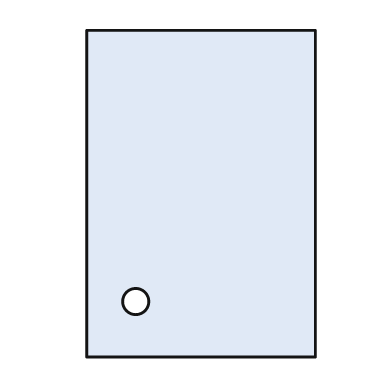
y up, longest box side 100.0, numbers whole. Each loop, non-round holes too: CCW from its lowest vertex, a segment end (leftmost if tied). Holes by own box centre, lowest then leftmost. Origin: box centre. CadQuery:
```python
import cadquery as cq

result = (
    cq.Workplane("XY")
    .moveTo(-35.0, -50.0)
    .lineTo(35.0, -50.0)
    .lineTo(35.0, 50.0)
    .lineTo(-35.0, 50.0)
    .close()
    .moveTo(-20.0, -33.0)
    .circle(4.0)
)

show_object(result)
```